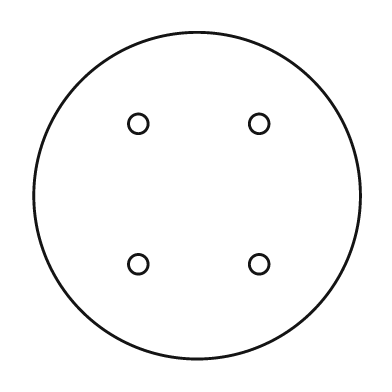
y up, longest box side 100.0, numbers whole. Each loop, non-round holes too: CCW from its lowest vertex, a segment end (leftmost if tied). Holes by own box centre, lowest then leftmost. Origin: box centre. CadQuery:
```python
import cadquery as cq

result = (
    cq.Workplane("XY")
    .moveTo(0.0, 0.0)
    .circle(50.0)
    .moveTo(-18.0, -21.0)
    .circle(3.0)
    .moveTo(19.0, -21.0)
    .circle(3.0)
    .moveTo(-18.0, 22.0)
    .circle(3.0)
    .moveTo(19.0, 22.0)
    .circle(3.0)
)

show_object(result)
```